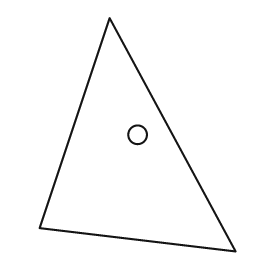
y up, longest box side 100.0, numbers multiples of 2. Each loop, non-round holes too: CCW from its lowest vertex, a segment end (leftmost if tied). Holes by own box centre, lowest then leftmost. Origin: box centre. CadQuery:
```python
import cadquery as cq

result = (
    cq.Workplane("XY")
    .moveTo(42.0, -50.0)
    .lineTo(-12.0, 50.0)
    .lineTo(-42.0, -40.0)
    .close()
    .moveTo(0.0, 0.0)
    .circle(4.0)
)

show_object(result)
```